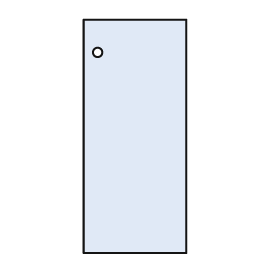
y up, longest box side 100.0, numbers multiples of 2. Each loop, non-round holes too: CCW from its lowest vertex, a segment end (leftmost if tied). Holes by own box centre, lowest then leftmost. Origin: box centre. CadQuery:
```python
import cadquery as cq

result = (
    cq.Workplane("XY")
    .moveTo(-22.0, -50.0)
    .lineTo(22.0, -50.0)
    .lineTo(22.0, 50.0)
    .lineTo(-22.0, 50.0)
    .close()
    .moveTo(-16.0, 36.0)
    .circle(2.0)
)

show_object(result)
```